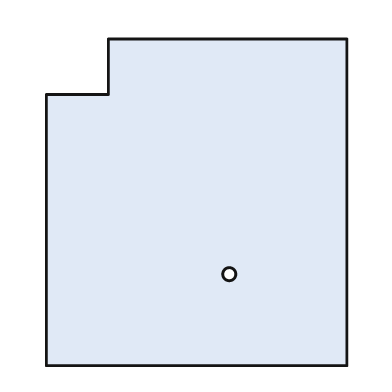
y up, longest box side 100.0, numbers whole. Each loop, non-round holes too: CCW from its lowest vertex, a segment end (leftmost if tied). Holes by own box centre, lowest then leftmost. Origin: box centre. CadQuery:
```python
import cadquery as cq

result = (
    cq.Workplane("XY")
    .moveTo(-46.0, -50.0)
    .lineTo(46.0, -50.0)
    .lineTo(46.0, 50.0)
    .lineTo(-27.0, 50.0)
    .lineTo(-27.0, 33.0)
    .lineTo(-46.0, 33.0)
    .close()
    .moveTo(10.0, -22.0)
    .circle(2.0)
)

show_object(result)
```